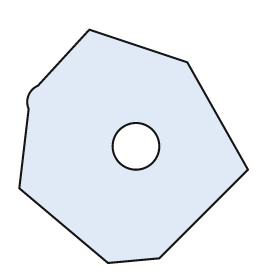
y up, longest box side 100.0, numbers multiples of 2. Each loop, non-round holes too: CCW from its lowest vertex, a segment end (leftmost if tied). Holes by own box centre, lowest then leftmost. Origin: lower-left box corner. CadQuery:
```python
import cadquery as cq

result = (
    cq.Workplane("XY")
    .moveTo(38.0, 0.0)
    .lineTo(60.0, 2.0)
    .lineTo(98.0, 40.0)
    .lineTo(72.0, 86.0)
    .lineTo(30.0, 100.0)
    .lineTo(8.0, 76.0)
    .threePointArc((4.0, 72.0), (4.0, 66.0))
    .lineTo(0.0, 32.0)
    .close()
    .moveTo(50.0, 50.0)
    .circle(10.0)
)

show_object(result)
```